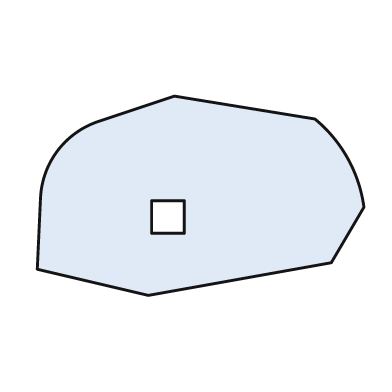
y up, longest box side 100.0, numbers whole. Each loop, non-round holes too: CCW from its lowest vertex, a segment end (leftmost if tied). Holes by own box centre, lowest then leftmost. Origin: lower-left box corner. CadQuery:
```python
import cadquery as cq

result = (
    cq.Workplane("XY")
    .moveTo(34.0, 0.0)
    .lineTo(90.0, 10.0)
    .lineTo(100.0, 27.0)
    .threePointArc((95.0, 42.0), (85.0, 54.0))
    .lineTo(42.0, 61.0)
    .lineTo(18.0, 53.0)
    .threePointArc((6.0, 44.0), (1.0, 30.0))
    .lineTo(0.0, 8.0)
    .close()
    .moveTo(35.0, 19.0)
    .lineTo(45.0, 19.0)
    .lineTo(45.0, 29.0)
    .lineTo(35.0, 29.0)
    .close()
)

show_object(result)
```